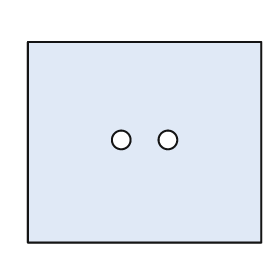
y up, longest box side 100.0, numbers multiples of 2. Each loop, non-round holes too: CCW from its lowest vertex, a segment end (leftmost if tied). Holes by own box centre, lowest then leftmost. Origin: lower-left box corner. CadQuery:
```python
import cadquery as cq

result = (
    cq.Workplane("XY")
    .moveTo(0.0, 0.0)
    .lineTo(100.0, 0.0)
    .lineTo(100.0, 86.0)
    .lineTo(0.0, 86.0)
    .close()
    .moveTo(40.0, 44.0)
    .circle(4.0)
    .moveTo(60.0, 44.0)
    .circle(4.0)
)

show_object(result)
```